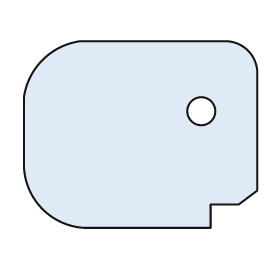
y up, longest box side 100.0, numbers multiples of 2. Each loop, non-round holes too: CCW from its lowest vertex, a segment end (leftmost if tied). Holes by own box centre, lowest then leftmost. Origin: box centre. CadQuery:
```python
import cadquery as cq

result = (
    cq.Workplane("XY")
    .moveTo(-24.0, -40.0)
    .lineTo(30.0, -40.0)
    .lineTo(30.0, -30.0)
    .lineTo(42.0, -30.0)
    .lineTo(50.0, -24.0)
    .lineTo(50.0, 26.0)
    .threePointArc((46.0, 36.0), (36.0, 40.0))
    .lineTo(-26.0, 40.0)
    .threePointArc((-42.0, 32.0), (-50.0, 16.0))
    .lineTo(-50.0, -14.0)
    .threePointArc((-42.0, -32.0), (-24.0, -40.0))
    .close()
    .moveTo(26.0, 10.0)
    .circle(6.0)
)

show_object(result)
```